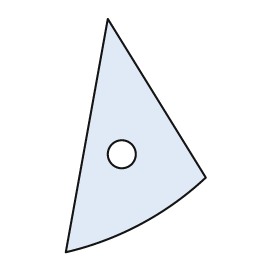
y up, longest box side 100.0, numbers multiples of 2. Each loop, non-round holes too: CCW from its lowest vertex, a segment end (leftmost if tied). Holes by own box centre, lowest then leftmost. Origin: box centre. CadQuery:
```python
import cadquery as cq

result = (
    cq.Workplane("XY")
    .moveTo(-30.0, -50.0)
    .threePointArc((2.0, -38.0), (30.0, -18.0))
    .lineTo(-12.0, 50.0)
    .close()
    .moveTo(-6.0, -8.0)
    .circle(6.0)
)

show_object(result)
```